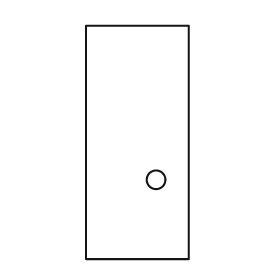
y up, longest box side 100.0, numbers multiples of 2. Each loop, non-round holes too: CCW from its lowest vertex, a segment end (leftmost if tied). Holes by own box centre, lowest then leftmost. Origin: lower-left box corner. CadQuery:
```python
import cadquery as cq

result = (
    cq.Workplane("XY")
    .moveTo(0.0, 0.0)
    .lineTo(44.0, 0.0)
    .lineTo(44.0, 100.0)
    .lineTo(0.0, 100.0)
    .close()
    .moveTo(30.0, 34.0)
    .circle(4.0)
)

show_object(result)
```